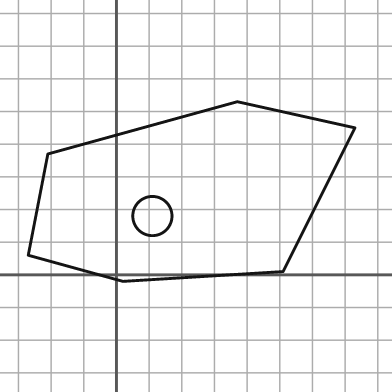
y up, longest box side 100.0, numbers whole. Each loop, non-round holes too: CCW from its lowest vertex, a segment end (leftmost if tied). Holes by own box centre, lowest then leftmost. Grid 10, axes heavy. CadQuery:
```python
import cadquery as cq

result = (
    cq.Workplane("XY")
    .moveTo(2.0, -2.0)
    .lineTo(51.0, 1.0)
    .lineTo(73.0, 45.0)
    .lineTo(37.0, 53.0)
    .lineTo(-21.0, 37.0)
    .lineTo(-27.0, 6.0)
    .close()
    .moveTo(11.0, 18.0)
    .circle(6.0)
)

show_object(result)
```